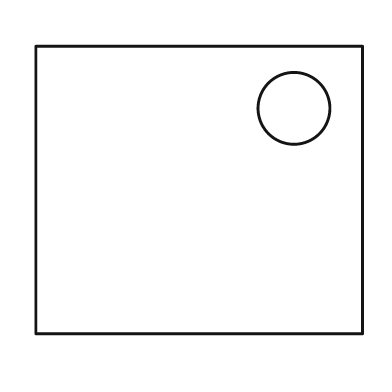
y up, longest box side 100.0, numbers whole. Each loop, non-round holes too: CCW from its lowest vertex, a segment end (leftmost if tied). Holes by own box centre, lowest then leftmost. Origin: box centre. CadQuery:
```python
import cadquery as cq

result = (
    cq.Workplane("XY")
    .moveTo(-50.0, -44.0)
    .lineTo(50.0, -44.0)
    .lineTo(50.0, 44.0)
    .lineTo(-50.0, 44.0)
    .close()
    .moveTo(29.0, 25.0)
    .circle(11.0)
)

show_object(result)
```